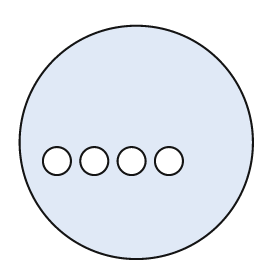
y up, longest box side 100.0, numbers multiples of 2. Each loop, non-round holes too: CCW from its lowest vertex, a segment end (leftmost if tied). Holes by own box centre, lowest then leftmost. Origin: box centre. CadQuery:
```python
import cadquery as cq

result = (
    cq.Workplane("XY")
    .moveTo(0.0, 0.0)
    .circle(50.0)
    .moveTo(-34.0, -8.0)
    .circle(6.0)
    .moveTo(-18.0, -8.0)
    .circle(6.0)
    .moveTo(-2.0, -8.0)
    .circle(6.0)
    .moveTo(14.0, -8.0)
    .circle(6.0)
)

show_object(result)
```